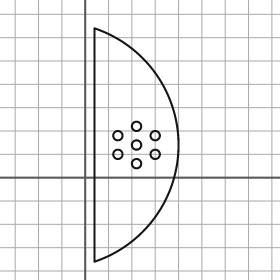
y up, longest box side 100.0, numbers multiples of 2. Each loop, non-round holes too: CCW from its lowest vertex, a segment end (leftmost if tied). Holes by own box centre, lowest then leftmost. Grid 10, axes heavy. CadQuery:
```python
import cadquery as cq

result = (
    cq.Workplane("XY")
    .moveTo(4.0, -36.0)
    .threePointArc((40.0, 14.0), (4.0, 64.0))
    .close()
    .moveTo(22.0, 6.0)
    .circle(2.0)
    .moveTo(14.0, 10.0)
    .circle(2.0)
    .moveTo(30.0, 10.0)
    .circle(2.0)
    .moveTo(22.0, 14.0)
    .circle(2.0)
    .moveTo(14.0, 18.0)
    .circle(2.0)
    .moveTo(30.0, 18.0)
    .circle(2.0)
    .moveTo(22.0, 22.0)
    .circle(2.0)
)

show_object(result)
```